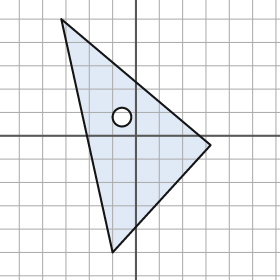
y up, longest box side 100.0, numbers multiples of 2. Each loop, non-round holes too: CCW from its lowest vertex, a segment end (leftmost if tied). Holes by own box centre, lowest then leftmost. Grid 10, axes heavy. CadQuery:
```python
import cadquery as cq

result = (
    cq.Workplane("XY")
    .moveTo(-10.0, -50.0)
    .lineTo(32.0, -4.0)
    .lineTo(-32.0, 50.0)
    .close()
    .moveTo(-6.0, 8.0)
    .circle(4.0)
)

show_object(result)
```